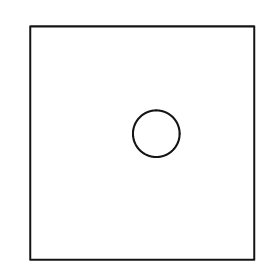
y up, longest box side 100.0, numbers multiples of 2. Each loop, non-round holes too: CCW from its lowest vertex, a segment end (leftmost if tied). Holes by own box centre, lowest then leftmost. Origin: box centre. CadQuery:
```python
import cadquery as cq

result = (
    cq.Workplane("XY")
    .moveTo(-48.0, -50.0)
    .lineTo(48.0, -50.0)
    .lineTo(48.0, 50.0)
    .lineTo(-48.0, 50.0)
    .close()
    .moveTo(6.0, 4.0)
    .circle(10.0)
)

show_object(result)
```